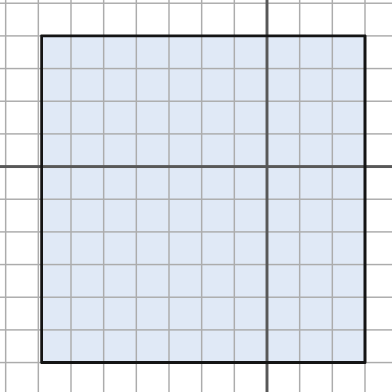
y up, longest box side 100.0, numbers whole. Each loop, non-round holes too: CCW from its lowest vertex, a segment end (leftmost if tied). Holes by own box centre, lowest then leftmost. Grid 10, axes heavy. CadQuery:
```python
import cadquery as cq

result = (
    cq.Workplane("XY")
    .moveTo(-69.0, -60.0)
    .lineTo(30.0, -60.0)
    .lineTo(30.0, 40.0)
    .lineTo(-69.0, 40.0)
    .close()
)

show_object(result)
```